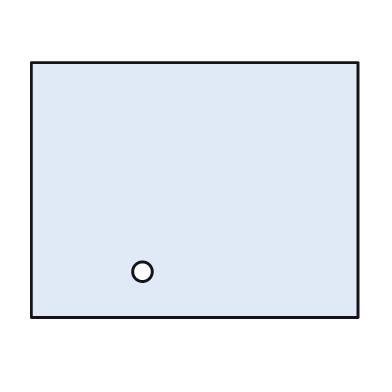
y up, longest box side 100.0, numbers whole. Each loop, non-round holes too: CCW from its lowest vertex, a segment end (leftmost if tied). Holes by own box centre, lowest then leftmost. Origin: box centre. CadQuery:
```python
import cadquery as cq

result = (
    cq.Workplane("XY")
    .moveTo(-50.0, -39.0)
    .lineTo(50.0, -39.0)
    .lineTo(50.0, 39.0)
    .lineTo(-50.0, 39.0)
    .close()
    .moveTo(-16.0, -25.0)
    .circle(3.0)
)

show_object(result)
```